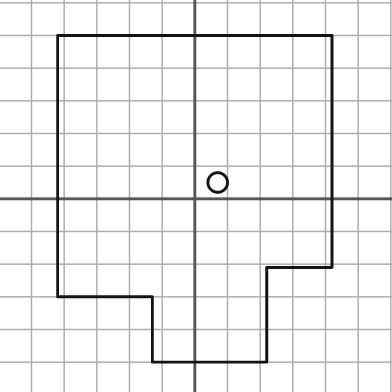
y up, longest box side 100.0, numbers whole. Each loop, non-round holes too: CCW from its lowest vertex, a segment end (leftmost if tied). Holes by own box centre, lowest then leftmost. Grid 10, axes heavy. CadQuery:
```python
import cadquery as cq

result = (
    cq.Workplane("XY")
    .moveTo(-13.0, -50.0)
    .lineTo(22.0, -50.0)
    .lineTo(22.0, -21.0)
    .lineTo(42.0, -21.0)
    .lineTo(42.0, 50.0)
    .lineTo(-42.0, 50.0)
    .lineTo(-42.0, -30.0)
    .lineTo(-13.0, -30.0)
    .close()
    .moveTo(7.0, 5.0)
    .circle(3.0)
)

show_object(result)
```